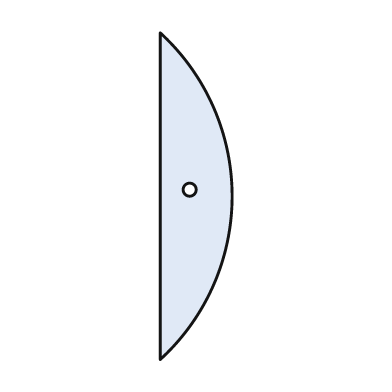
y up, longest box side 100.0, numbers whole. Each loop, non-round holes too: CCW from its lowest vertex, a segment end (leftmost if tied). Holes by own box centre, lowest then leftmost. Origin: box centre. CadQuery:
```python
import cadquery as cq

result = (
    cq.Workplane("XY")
    .moveTo(-11.0, -50.0)
    .threePointArc((11.0, 0.0), (-11.0, 50.0))
    .close()
    .moveTo(-2.0, 2.0)
    .circle(2.0)
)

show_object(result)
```